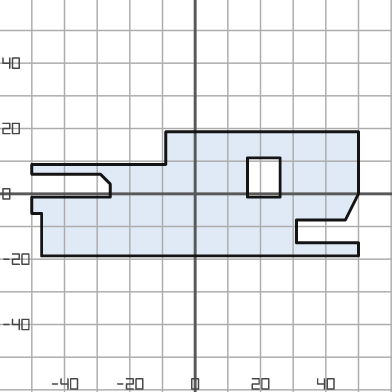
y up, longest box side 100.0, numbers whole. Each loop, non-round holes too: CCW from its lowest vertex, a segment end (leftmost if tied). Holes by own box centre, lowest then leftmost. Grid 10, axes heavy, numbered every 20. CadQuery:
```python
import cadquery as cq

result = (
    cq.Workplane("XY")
    .moveTo(-47.0, -19.0)
    .lineTo(50.0, -19.0)
    .lineTo(50.0, -15.0)
    .lineTo(31.0, -15.0)
    .lineTo(31.0, -8.0)
    .lineTo(46.0, -8.0)
    .lineTo(50.0, 0.0)
    .lineTo(50.0, 19.0)
    .lineTo(-9.0, 19.0)
    .lineTo(-9.0, 9.0)
    .lineTo(-50.0, 9.0)
    .lineTo(-50.0, 6.0)
    .lineTo(-29.0, 6.0)
    .lineTo(-26.0, 3.0)
    .lineTo(-26.0, -1.0)
    .lineTo(-50.0, -1.0)
    .lineTo(-50.0, -6.0)
    .lineTo(-47.0, -6.0)
    .close()
    .moveTo(16.0, -1.0)
    .lineTo(26.0, -1.0)
    .lineTo(26.0, 11.0)
    .lineTo(16.0, 11.0)
    .close()
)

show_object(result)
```